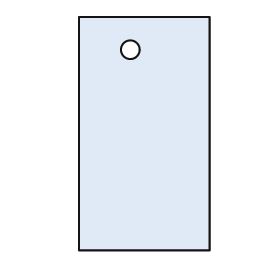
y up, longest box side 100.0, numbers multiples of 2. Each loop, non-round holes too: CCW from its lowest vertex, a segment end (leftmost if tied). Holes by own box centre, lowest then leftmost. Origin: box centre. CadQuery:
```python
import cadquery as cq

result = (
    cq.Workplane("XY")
    .moveTo(-28.0, -50.0)
    .lineTo(28.0, -50.0)
    .lineTo(28.0, 50.0)
    .lineTo(-28.0, 50.0)
    .close()
    .moveTo(-6.0, 36.0)
    .circle(4.0)
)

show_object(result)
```